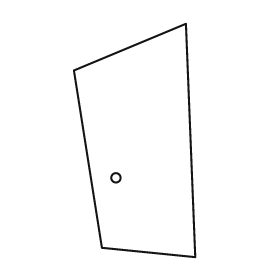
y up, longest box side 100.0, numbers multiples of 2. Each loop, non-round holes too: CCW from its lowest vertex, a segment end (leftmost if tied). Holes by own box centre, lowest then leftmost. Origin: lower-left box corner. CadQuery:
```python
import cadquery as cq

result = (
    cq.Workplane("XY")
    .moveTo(52.0, 0.0)
    .lineTo(48.0, 100.0)
    .lineTo(0.0, 80.0)
    .lineTo(12.0, 4.0)
    .close()
    .moveTo(18.0, 34.0)
    .circle(2.0)
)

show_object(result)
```